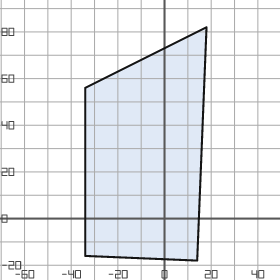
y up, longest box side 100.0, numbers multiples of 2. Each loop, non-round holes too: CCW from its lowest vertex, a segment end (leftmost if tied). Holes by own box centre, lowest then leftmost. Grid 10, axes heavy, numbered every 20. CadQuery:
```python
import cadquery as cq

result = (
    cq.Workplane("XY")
    .moveTo(14.0, -18.0)
    .lineTo(18.0, 82.0)
    .lineTo(-34.0, 56.0)
    .lineTo(-34.0, -16.0)
    .close()
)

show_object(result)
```